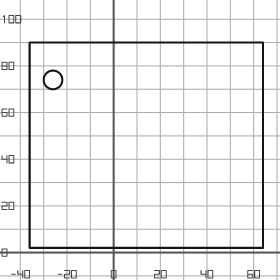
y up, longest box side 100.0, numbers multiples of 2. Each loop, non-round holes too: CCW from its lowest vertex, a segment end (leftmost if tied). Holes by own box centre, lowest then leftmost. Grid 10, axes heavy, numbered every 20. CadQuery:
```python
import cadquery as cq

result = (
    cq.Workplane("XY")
    .moveTo(-36.0, 2.0)
    .lineTo(64.0, 2.0)
    .lineTo(64.0, 90.0)
    .lineTo(-36.0, 90.0)
    .close()
    .moveTo(-26.0, 74.0)
    .circle(4.0)
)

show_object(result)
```